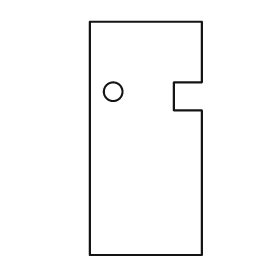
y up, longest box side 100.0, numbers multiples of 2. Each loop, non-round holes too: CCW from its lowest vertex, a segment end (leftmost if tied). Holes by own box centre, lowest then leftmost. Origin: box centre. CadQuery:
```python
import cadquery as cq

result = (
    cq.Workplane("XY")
    .moveTo(-24.0, -50.0)
    .lineTo(24.0, -50.0)
    .lineTo(24.0, 12.0)
    .lineTo(12.0, 12.0)
    .lineTo(12.0, 24.0)
    .lineTo(24.0, 24.0)
    .lineTo(24.0, 50.0)
    .lineTo(-24.0, 50.0)
    .close()
    .moveTo(-14.0, 20.0)
    .circle(4.0)
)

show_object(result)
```